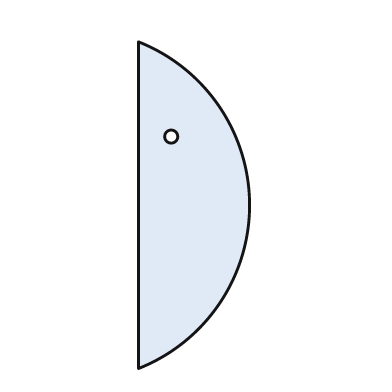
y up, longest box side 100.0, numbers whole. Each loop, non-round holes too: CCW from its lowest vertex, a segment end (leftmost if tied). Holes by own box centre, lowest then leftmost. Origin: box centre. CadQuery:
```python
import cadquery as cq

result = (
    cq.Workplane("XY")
    .moveTo(-17.0, -50.0)
    .threePointArc((17.0, 0.0), (-17.0, 50.0))
    .close()
    .moveTo(-7.0, 21.0)
    .circle(2.0)
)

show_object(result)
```